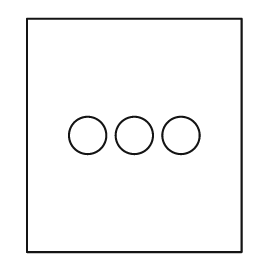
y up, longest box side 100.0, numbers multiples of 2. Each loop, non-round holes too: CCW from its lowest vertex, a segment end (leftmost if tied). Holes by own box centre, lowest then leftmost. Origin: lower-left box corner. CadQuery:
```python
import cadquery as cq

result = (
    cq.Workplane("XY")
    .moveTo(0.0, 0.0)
    .lineTo(92.0, 0.0)
    .lineTo(92.0, 100.0)
    .lineTo(0.0, 100.0)
    .close()
    .moveTo(26.0, 50.0)
    .circle(8.0)
    .moveTo(46.0, 50.0)
    .circle(8.0)
    .moveTo(66.0, 50.0)
    .circle(8.0)
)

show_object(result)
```